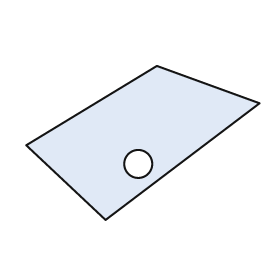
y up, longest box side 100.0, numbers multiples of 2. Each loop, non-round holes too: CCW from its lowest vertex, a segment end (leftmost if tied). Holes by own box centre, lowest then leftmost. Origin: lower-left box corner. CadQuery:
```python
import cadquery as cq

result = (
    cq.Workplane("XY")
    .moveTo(34.0, 0.0)
    .lineTo(100.0, 50.0)
    .lineTo(56.0, 66.0)
    .lineTo(0.0, 32.0)
    .close()
    .moveTo(48.0, 24.0)
    .circle(6.0)
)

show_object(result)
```